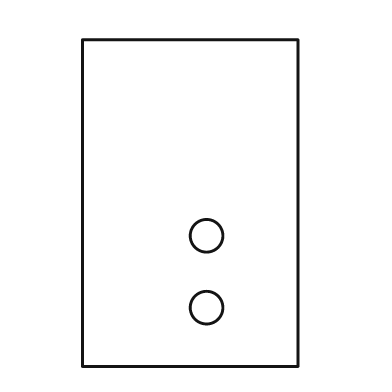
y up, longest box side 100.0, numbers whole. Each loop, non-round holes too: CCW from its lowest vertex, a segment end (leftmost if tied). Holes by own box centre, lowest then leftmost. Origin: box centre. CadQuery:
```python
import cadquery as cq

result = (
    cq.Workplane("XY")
    .moveTo(-33.0, -50.0)
    .lineTo(33.0, -50.0)
    .lineTo(33.0, 50.0)
    .lineTo(-33.0, 50.0)
    .close()
    .moveTo(5.0, -32.0)
    .circle(5.0)
    .moveTo(5.0, -10.0)
    .circle(5.0)
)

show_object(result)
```